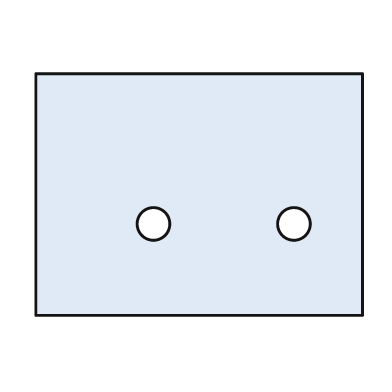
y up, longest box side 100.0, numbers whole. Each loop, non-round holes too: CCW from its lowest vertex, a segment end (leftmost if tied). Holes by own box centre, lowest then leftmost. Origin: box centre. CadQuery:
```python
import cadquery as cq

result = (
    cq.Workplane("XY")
    .moveTo(-50.0, -37.0)
    .lineTo(50.0, -37.0)
    .lineTo(50.0, 37.0)
    .lineTo(-50.0, 37.0)
    .close()
    .moveTo(-14.0, -9.0)
    .circle(5.0)
    .moveTo(29.0, -9.0)
    .circle(5.0)
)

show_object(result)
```